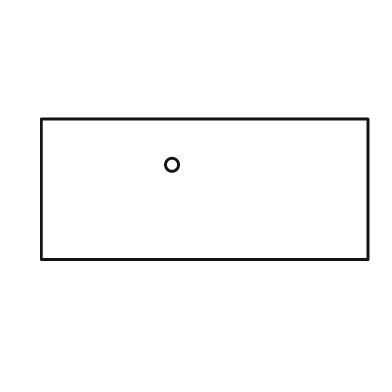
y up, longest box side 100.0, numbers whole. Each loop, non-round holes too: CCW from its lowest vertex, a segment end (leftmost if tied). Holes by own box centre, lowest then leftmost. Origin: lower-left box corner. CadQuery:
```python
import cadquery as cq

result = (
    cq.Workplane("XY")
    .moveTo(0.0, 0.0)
    .lineTo(100.0, 0.0)
    .lineTo(100.0, 43.0)
    .lineTo(0.0, 43.0)
    .close()
    .moveTo(40.0, 29.0)
    .circle(2.0)
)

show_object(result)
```